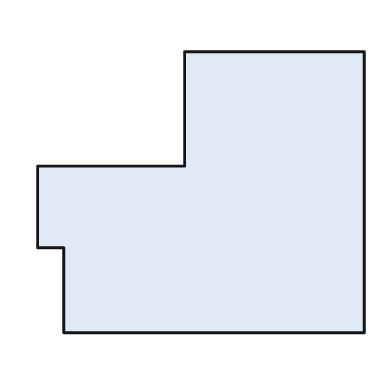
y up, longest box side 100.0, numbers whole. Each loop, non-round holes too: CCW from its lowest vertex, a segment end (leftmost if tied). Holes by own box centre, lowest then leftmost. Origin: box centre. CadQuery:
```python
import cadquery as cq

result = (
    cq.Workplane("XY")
    .moveTo(-42.0, -43.0)
    .lineTo(50.0, -43.0)
    .lineTo(50.0, 43.0)
    .lineTo(-5.0, 43.0)
    .lineTo(-5.0, 8.0)
    .lineTo(-50.0, 8.0)
    .lineTo(-50.0, -17.0)
    .lineTo(-42.0, -17.0)
    .close()
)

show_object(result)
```